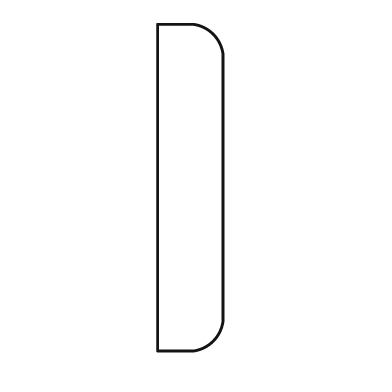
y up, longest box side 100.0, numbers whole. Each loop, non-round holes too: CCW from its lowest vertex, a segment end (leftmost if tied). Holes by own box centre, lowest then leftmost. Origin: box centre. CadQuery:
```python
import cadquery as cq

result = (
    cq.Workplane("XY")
    .moveTo(-10.0, -50.0)
    .lineTo(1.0, -50.0)
    .threePointArc((7.0, -47.0), (10.0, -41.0))
    .lineTo(10.0, 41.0)
    .threePointArc((7.0, 47.0), (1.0, 50.0))
    .lineTo(-10.0, 50.0)
    .close()
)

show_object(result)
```